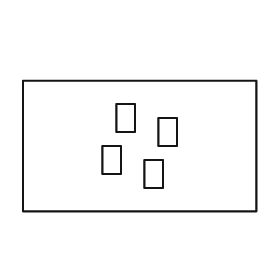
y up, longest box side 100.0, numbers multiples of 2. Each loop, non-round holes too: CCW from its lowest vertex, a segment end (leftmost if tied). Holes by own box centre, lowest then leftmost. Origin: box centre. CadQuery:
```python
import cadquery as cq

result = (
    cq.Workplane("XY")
    .moveTo(-50.0, -28.0)
    .lineTo(50.0, -28.0)
    .lineTo(50.0, 28.0)
    .lineTo(-50.0, 28.0)
    .close()
    .moveTo(2.0, -18.0)
    .lineTo(10.0, -18.0)
    .lineTo(10.0, -6.0)
    .lineTo(2.0, -6.0)
    .close()
    .moveTo(-16.0, -12.0)
    .lineTo(-8.0, -12.0)
    .lineTo(-8.0, 0.0)
    .lineTo(-16.0, 0.0)
    .close()
    .moveTo(8.0, 0.0)
    .lineTo(16.0, 0.0)
    .lineTo(16.0, 12.0)
    .lineTo(8.0, 12.0)
    .close()
    .moveTo(-10.0, 6.0)
    .lineTo(-2.0, 6.0)
    .lineTo(-2.0, 18.0)
    .lineTo(-10.0, 18.0)
    .close()
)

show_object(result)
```